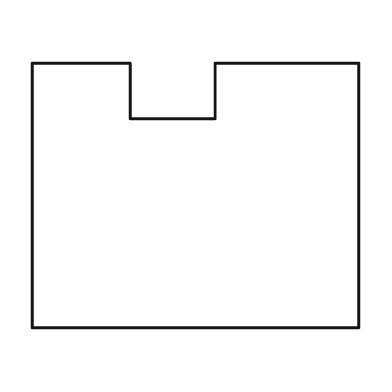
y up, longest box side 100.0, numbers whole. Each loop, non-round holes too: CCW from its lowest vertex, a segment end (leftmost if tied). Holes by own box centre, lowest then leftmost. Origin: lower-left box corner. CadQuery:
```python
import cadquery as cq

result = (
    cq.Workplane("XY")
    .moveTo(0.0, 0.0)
    .lineTo(100.0, 0.0)
    .lineTo(100.0, 81.0)
    .lineTo(56.0, 81.0)
    .lineTo(56.0, 64.0)
    .lineTo(30.0, 64.0)
    .lineTo(30.0, 81.0)
    .lineTo(0.0, 81.0)
    .close()
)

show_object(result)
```